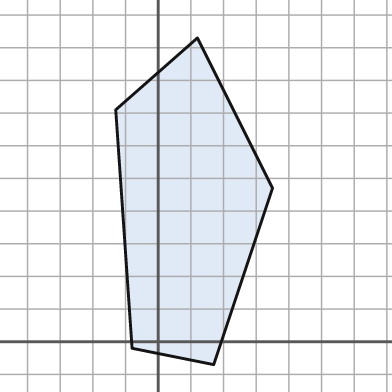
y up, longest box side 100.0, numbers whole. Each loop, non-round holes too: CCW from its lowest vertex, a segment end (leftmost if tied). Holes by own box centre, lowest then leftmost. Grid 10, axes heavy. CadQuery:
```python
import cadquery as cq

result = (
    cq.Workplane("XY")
    .moveTo(17.0, -7.0)
    .lineTo(35.0, 47.0)
    .lineTo(12.0, 93.0)
    .lineTo(-13.0, 71.0)
    .lineTo(-8.0, -2.0)
    .close()
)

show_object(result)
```